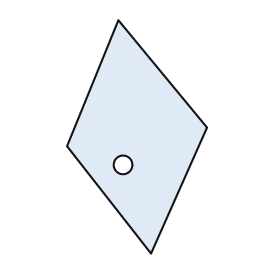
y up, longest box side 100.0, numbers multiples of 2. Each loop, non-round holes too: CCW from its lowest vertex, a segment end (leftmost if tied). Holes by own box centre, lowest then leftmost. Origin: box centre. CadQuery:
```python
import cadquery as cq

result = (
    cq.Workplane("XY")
    .moveTo(6.0, -50.0)
    .lineTo(30.0, 4.0)
    .lineTo(-8.0, 50.0)
    .lineTo(-30.0, -4.0)
    .close()
    .moveTo(-6.0, -12.0)
    .circle(4.0)
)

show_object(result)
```